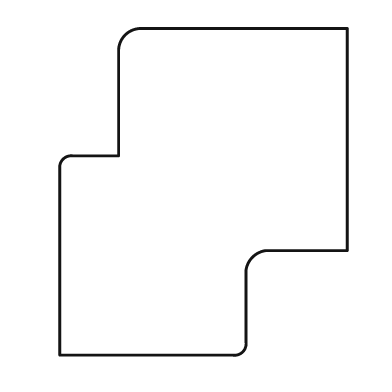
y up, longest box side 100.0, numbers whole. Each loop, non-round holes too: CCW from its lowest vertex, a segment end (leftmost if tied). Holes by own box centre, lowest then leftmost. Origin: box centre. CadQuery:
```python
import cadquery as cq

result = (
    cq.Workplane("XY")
    .moveTo(-44.0, -50.0)
    .lineTo(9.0, -50.0)
    .threePointArc((12.0, -49.0), (13.0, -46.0))
    .lineTo(13.0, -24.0)
    .threePointArc((15.0, -20.0), (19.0, -18.0))
    .lineTo(44.0, -18.0)
    .lineTo(44.0, 50.0)
    .lineTo(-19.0, 50.0)
    .threePointArc((-24.0, 48.0), (-26.0, 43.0))
    .lineTo(-26.0, 11.0)
    .lineTo(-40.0, 11.0)
    .threePointArc((-43.0, 10.0), (-44.0, 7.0))
    .close()
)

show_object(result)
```